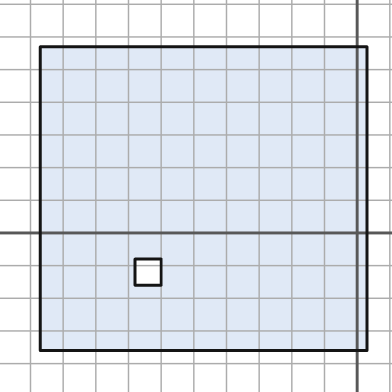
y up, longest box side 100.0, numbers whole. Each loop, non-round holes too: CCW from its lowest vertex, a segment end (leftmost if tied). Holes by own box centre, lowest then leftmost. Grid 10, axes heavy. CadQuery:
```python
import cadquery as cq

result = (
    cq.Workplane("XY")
    .moveTo(-97.0, -36.0)
    .lineTo(3.0, -36.0)
    .lineTo(3.0, 57.0)
    .lineTo(-97.0, 57.0)
    .close()
    .moveTo(-68.0, -16.0)
    .lineTo(-60.0, -16.0)
    .lineTo(-60.0, -8.0)
    .lineTo(-68.0, -8.0)
    .close()
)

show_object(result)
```